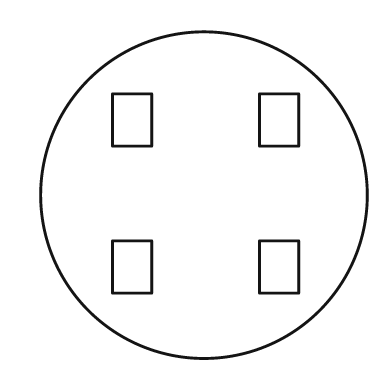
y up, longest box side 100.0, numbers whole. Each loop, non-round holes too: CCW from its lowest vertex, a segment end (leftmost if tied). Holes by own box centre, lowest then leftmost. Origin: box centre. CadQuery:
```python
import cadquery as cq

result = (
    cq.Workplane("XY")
    .moveTo(0.0, 0.0)
    .circle(50.0)
    .moveTo(-28.0, -30.0)
    .lineTo(-16.0, -30.0)
    .lineTo(-16.0, -14.0)
    .lineTo(-28.0, -14.0)
    .close()
    .moveTo(17.0, -30.0)
    .lineTo(29.0, -30.0)
    .lineTo(29.0, -14.0)
    .lineTo(17.0, -14.0)
    .close()
    .moveTo(-28.0, 15.0)
    .lineTo(-16.0, 15.0)
    .lineTo(-16.0, 31.0)
    .lineTo(-28.0, 31.0)
    .close()
    .moveTo(17.0, 15.0)
    .lineTo(29.0, 15.0)
    .lineTo(29.0, 31.0)
    .lineTo(17.0, 31.0)
    .close()
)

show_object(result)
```